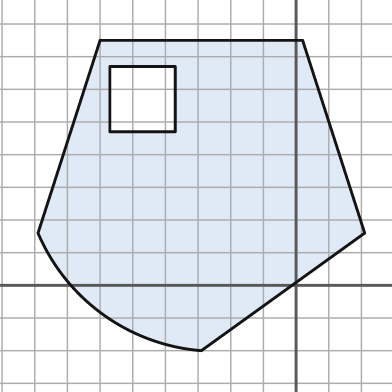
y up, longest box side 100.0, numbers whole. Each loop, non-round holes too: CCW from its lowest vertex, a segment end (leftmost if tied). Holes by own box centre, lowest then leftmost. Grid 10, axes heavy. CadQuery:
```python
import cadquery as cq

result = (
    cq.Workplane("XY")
    .moveTo(-29.0, -20.0)
    .lineTo(21.0, 16.0)
    .lineTo(2.0, 75.0)
    .lineTo(-60.0, 75.0)
    .lineTo(-79.0, 16.0)
    .threePointArc((-59.0, -9.0), (-29.0, -20.0))
    .close()
    .moveTo(-57.0, 47.0)
    .lineTo(-37.0, 47.0)
    .lineTo(-37.0, 67.0)
    .lineTo(-57.0, 67.0)
    .close()
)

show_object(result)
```